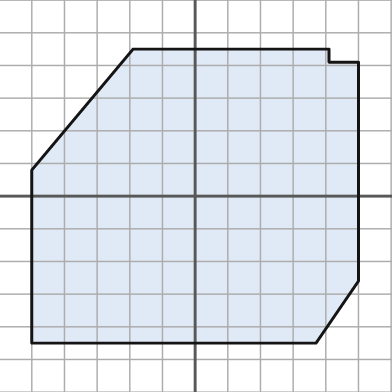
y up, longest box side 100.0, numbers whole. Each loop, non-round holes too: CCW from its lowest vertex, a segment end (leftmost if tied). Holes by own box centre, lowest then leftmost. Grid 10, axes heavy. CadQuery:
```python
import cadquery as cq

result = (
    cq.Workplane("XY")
    .moveTo(-50.0, -45.0)
    .lineTo(37.0, -45.0)
    .lineTo(50.0, -26.0)
    .lineTo(50.0, 41.0)
    .lineTo(41.0, 41.0)
    .lineTo(41.0, 45.0)
    .lineTo(-19.0, 45.0)
    .lineTo(-50.0, 8.0)
    .close()
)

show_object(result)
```